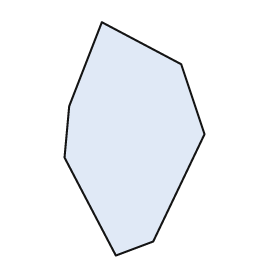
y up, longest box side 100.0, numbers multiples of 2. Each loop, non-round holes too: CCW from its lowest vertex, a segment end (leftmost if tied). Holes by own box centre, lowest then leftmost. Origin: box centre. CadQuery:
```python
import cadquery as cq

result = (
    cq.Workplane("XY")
    .moveTo(-8.0, -50.0)
    .lineTo(8.0, -44.0)
    .lineTo(30.0, 2.0)
    .lineTo(20.0, 32.0)
    .lineTo(-14.0, 50.0)
    .lineTo(-28.0, 14.0)
    .lineTo(-30.0, -8.0)
    .close()
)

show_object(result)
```